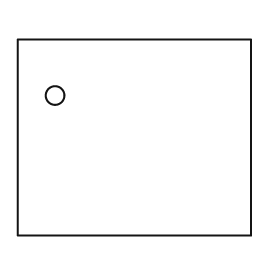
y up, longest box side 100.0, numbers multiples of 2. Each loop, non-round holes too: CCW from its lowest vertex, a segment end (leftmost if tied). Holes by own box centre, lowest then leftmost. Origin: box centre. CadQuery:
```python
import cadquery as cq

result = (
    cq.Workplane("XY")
    .moveTo(-50.0, -42.0)
    .lineTo(50.0, -42.0)
    .lineTo(50.0, 42.0)
    .lineTo(-50.0, 42.0)
    .close()
    .moveTo(-34.0, 18.0)
    .circle(4.0)
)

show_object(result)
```